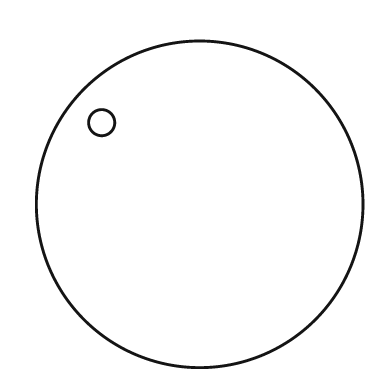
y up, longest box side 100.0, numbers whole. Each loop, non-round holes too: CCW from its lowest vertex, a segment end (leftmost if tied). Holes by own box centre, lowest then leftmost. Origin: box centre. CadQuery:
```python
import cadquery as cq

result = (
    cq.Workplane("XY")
    .moveTo(0.0, 0.0)
    .circle(50.0)
    .moveTo(-30.0, 25.0)
    .circle(4.0)
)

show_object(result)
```